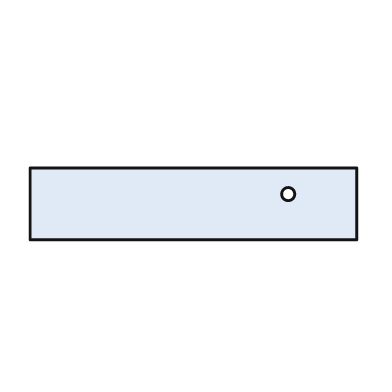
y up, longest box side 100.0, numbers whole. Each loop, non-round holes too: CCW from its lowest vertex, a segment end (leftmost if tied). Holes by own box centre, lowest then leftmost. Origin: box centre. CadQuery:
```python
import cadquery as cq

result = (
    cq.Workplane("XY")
    .moveTo(-50.0, -11.0)
    .lineTo(50.0, -11.0)
    .lineTo(50.0, 11.0)
    .lineTo(-50.0, 11.0)
    .close()
    .moveTo(29.0, 3.0)
    .circle(2.0)
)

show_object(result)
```